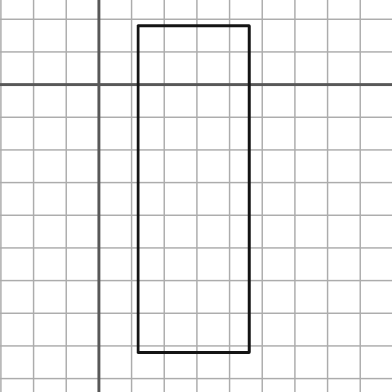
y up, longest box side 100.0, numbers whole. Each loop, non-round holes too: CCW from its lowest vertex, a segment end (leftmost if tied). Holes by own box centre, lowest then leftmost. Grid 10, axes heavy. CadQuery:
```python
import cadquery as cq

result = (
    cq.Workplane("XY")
    .moveTo(12.0, -82.0)
    .lineTo(46.0, -82.0)
    .lineTo(46.0, 18.0)
    .lineTo(12.0, 18.0)
    .close()
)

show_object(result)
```